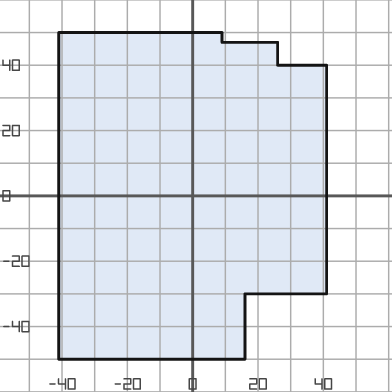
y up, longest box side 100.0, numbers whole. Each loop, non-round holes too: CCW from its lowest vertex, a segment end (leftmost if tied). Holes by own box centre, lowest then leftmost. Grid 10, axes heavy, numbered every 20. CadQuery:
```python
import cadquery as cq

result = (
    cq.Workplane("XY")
    .moveTo(-41.0, -50.0)
    .lineTo(16.0, -50.0)
    .lineTo(16.0, -30.0)
    .lineTo(41.0, -30.0)
    .lineTo(41.0, 40.0)
    .lineTo(26.0, 40.0)
    .lineTo(26.0, 47.0)
    .lineTo(9.0, 47.0)
    .lineTo(9.0, 50.0)
    .lineTo(-41.0, 50.0)
    .close()
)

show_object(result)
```